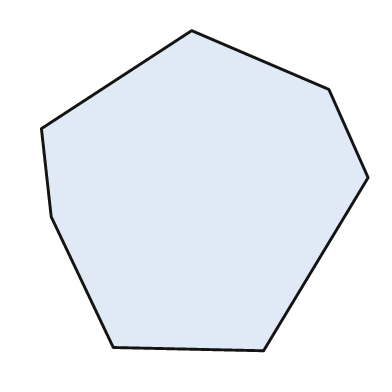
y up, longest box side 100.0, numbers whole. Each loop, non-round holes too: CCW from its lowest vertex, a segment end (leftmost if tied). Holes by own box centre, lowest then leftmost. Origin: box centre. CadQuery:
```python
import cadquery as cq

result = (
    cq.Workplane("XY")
    .moveTo(18.0, -49.0)
    .lineTo(50.0, 4.0)
    .lineTo(38.0, 31.0)
    .lineTo(-4.0, 49.0)
    .lineTo(-50.0, 19.0)
    .lineTo(-47.0, -8.0)
    .lineTo(-28.0, -48.0)
    .close()
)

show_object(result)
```